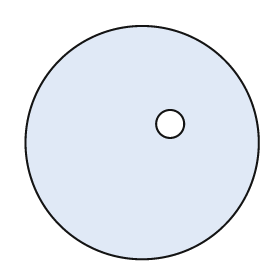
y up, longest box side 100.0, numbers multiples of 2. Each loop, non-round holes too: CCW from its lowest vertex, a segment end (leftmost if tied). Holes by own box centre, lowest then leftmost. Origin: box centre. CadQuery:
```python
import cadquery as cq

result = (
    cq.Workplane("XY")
    .moveTo(0.0, 0.0)
    .circle(50.0)
    .moveTo(12.0, 8.0)
    .circle(6.0)
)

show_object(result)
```